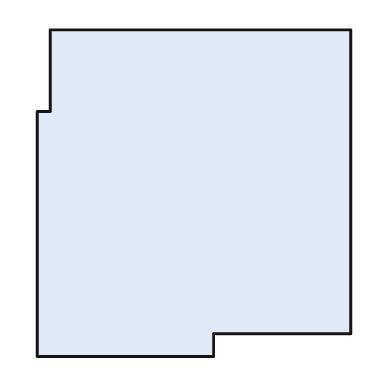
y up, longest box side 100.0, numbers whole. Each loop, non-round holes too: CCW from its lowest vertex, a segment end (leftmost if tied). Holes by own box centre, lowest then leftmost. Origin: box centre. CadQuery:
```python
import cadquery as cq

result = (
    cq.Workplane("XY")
    .moveTo(-48.0, -50.0)
    .lineTo(6.0, -50.0)
    .lineTo(6.0, -43.0)
    .lineTo(48.0, -43.0)
    .lineTo(48.0, 50.0)
    .lineTo(-44.0, 50.0)
    .lineTo(-44.0, 25.0)
    .lineTo(-48.0, 25.0)
    .close()
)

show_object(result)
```